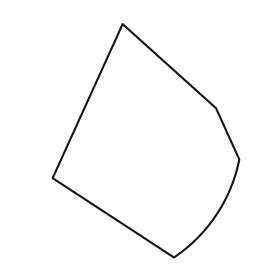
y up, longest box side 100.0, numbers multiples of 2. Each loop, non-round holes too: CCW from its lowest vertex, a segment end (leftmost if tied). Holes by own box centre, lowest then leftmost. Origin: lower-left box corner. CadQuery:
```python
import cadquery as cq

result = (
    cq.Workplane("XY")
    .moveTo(52.0, 0.0)
    .threePointArc((70.0, 18.0), (80.0, 42.0))
    .lineTo(70.0, 64.0)
    .lineTo(30.0, 100.0)
    .lineTo(0.0, 34.0)
    .close()
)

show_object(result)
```